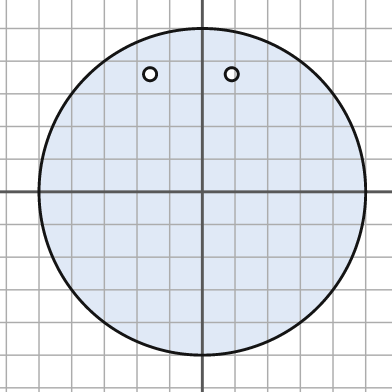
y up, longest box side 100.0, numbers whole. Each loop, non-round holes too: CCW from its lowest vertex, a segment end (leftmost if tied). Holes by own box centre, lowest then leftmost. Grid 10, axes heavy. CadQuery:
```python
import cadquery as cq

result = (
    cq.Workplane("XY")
    .moveTo(0.0, 0.0)
    .circle(50.0)
    .moveTo(-16.0, 36.0)
    .circle(2.0)
    .moveTo(9.0, 36.0)
    .circle(2.0)
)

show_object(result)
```